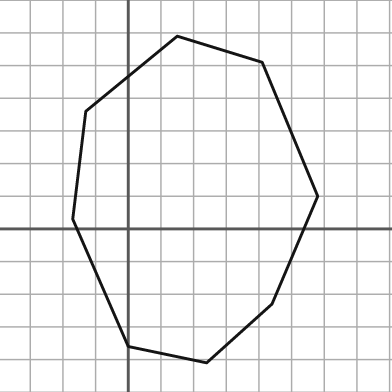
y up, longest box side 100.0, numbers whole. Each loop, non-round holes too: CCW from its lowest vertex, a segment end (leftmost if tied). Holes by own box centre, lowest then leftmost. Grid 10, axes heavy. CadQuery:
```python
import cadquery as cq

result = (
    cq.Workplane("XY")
    .moveTo(24.0, -41.0)
    .lineTo(44.0, -23.0)
    .lineTo(58.0, 10.0)
    .lineTo(41.0, 51.0)
    .lineTo(15.0, 59.0)
    .lineTo(-13.0, 36.0)
    .lineTo(-17.0, 3.0)
    .lineTo(0.0, -36.0)
    .close()
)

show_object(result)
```